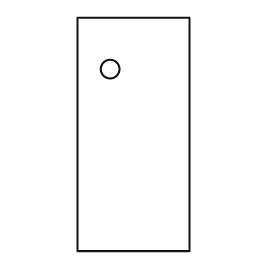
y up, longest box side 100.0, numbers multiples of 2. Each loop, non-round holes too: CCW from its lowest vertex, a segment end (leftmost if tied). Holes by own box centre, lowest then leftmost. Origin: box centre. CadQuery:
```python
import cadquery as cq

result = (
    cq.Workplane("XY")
    .moveTo(-24.0, -50.0)
    .lineTo(24.0, -50.0)
    .lineTo(24.0, 50.0)
    .lineTo(-24.0, 50.0)
    .close()
    .moveTo(-10.0, 28.0)
    .circle(4.0)
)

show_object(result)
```